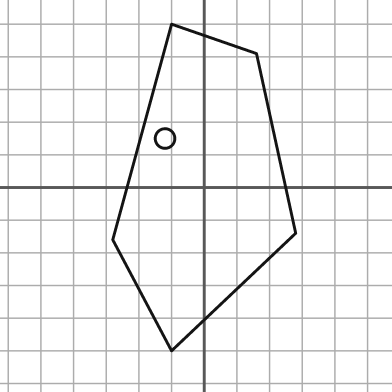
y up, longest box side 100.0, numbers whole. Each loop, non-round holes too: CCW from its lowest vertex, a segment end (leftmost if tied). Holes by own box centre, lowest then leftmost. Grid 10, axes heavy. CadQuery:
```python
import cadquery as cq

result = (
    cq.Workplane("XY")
    .moveTo(-10.0, -50.0)
    .lineTo(28.0, -14.0)
    .lineTo(16.0, 41.0)
    .lineTo(-10.0, 50.0)
    .lineTo(-28.0, -16.0)
    .close()
    .moveTo(-12.0, 15.0)
    .circle(3.0)
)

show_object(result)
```